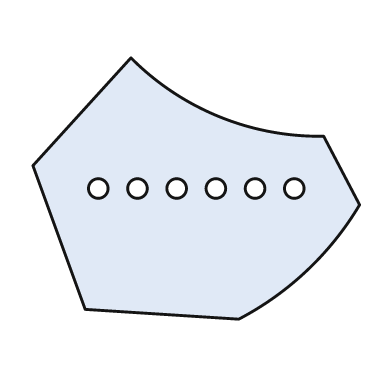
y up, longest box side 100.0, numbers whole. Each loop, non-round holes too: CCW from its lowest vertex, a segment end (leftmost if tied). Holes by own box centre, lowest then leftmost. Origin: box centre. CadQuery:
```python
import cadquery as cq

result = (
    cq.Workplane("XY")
    .moveTo(13.0, -40.0)
    .threePointArc((34.0, -25.0), (50.0, -5.0))
    .lineTo(39.0, 16.0)
    .threePointArc((7.0, 22.0), (-20.0, 40.0))
    .lineTo(-50.0, 7.0)
    .lineTo(-34.0, -37.0)
    .close()
    .moveTo(-30.0, 0.0)
    .circle(3.0)
    .moveTo(-18.0, 0.0)
    .circle(3.0)
    .moveTo(-6.0, 0.0)
    .circle(3.0)
    .moveTo(6.0, 0.0)
    .circle(3.0)
    .moveTo(18.0, 0.0)
    .circle(3.0)
    .moveTo(30.0, 0.0)
    .circle(3.0)
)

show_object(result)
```